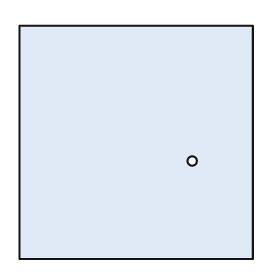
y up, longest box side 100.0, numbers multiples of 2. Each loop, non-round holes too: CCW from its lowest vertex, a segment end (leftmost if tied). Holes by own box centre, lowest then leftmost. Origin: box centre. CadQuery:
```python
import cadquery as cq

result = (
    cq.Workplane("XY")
    .moveTo(-50.0, -50.0)
    .lineTo(50.0, -50.0)
    .lineTo(50.0, 50.0)
    .lineTo(-50.0, 50.0)
    .close()
    .moveTo(24.0, -8.0)
    .circle(2.0)
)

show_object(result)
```